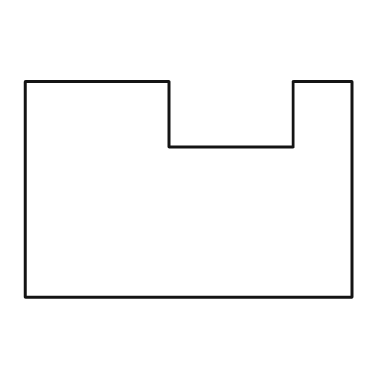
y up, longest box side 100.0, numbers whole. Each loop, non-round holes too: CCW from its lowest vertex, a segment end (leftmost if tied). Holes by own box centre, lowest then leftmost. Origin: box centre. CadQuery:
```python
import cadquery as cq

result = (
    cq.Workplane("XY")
    .moveTo(-50.0, -33.0)
    .lineTo(50.0, -33.0)
    .lineTo(50.0, 33.0)
    .lineTo(32.0, 33.0)
    .lineTo(32.0, 13.0)
    .lineTo(-6.0, 13.0)
    .lineTo(-6.0, 33.0)
    .lineTo(-50.0, 33.0)
    .close()
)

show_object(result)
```